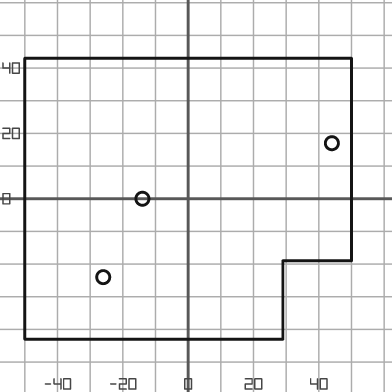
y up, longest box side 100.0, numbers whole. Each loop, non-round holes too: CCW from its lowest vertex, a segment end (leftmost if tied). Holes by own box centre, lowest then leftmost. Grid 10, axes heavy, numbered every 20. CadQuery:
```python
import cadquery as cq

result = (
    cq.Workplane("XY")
    .moveTo(-50.0, -43.0)
    .lineTo(29.0, -43.0)
    .lineTo(29.0, -19.0)
    .lineTo(50.0, -19.0)
    .lineTo(50.0, 43.0)
    .lineTo(-50.0, 43.0)
    .close()
    .moveTo(-26.0, -24.0)
    .circle(2.0)
    .moveTo(-14.0, 0.0)
    .circle(2.0)
    .moveTo(44.0, 17.0)
    .circle(2.0)
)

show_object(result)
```